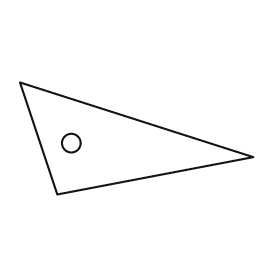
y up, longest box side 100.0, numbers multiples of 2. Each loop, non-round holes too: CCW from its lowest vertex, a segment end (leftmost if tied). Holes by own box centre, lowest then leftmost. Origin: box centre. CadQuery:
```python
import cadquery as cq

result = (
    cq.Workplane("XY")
    .moveTo(-34.0, -24.0)
    .lineTo(50.0, -8.0)
    .lineTo(-50.0, 24.0)
    .close()
    .moveTo(-28.0, -2.0)
    .circle(4.0)
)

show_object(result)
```